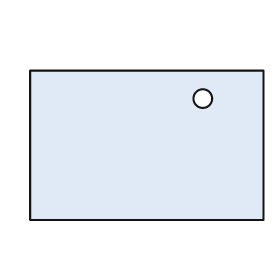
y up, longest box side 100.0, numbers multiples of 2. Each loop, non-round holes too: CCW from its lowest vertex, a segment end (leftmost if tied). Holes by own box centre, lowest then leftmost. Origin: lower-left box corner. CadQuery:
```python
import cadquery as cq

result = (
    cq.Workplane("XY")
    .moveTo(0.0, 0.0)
    .lineTo(100.0, 0.0)
    .lineTo(100.0, 64.0)
    .lineTo(0.0, 64.0)
    .close()
    .moveTo(74.0, 52.0)
    .circle(4.0)
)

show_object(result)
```